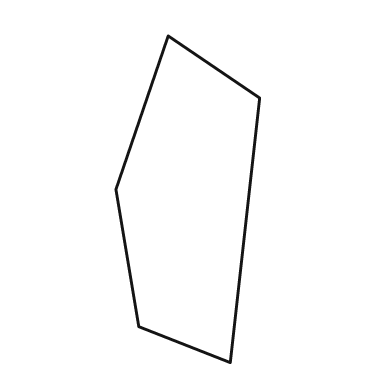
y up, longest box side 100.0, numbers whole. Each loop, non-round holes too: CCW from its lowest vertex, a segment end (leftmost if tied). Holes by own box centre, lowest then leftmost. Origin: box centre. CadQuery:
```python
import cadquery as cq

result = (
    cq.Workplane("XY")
    .moveTo(13.0, -50.0)
    .lineTo(22.0, 31.0)
    .lineTo(-6.0, 50.0)
    .lineTo(-22.0, 3.0)
    .lineTo(-15.0, -39.0)
    .close()
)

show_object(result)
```